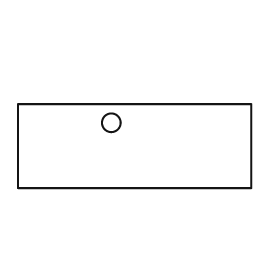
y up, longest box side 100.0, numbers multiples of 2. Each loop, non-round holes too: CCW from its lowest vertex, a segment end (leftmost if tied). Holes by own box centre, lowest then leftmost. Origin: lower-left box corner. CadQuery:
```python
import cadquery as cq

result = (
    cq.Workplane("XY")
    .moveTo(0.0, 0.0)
    .lineTo(100.0, 0.0)
    .lineTo(100.0, 36.0)
    .lineTo(0.0, 36.0)
    .close()
    .moveTo(40.0, 28.0)
    .circle(4.0)
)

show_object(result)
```